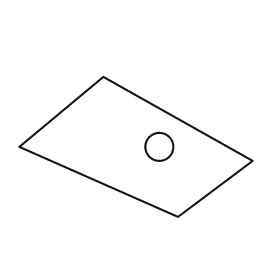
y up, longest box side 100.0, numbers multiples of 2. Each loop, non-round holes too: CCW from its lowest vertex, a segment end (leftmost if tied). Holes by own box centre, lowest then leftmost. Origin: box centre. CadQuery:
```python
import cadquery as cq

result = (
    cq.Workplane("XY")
    .moveTo(18.0, -30.0)
    .lineTo(50.0, -6.0)
    .lineTo(-14.0, 30.0)
    .lineTo(-50.0, 0.0)
    .close()
    .moveTo(10.0, 0.0)
    .circle(6.0)
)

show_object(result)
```